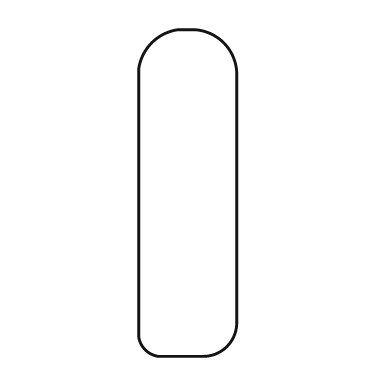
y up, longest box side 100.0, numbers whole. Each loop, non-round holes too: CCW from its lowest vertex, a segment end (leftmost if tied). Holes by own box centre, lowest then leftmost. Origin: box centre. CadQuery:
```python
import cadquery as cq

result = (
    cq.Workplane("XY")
    .moveTo(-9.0, -50.0)
    .lineTo(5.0, -50.0)
    .threePointArc((12.0, -47.0), (15.0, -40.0))
    .lineTo(15.0, 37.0)
    .threePointArc((11.0, 46.0), (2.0, 50.0))
    .lineTo(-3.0, 50.0)
    .threePointArc((-11.0, 46.0), (-15.0, 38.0))
    .lineTo(-15.0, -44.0)
    .threePointArc((-13.0, -48.0), (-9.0, -50.0))
    .close()
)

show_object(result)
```